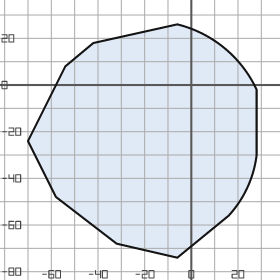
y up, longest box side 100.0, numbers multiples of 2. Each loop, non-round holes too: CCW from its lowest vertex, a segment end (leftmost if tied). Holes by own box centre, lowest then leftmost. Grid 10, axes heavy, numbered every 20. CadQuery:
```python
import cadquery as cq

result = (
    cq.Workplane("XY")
    .moveTo(-6.0, -74.0)
    .lineTo(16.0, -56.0)
    .threePointArc((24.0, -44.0), (28.0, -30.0))
    .lineTo(28.0, -2.0)
    .threePointArc((14.0, 16.0), (-6.0, 26.0))
    .lineTo(-42.0, 18.0)
    .lineTo(-54.0, 8.0)
    .lineTo(-70.0, -24.0)
    .lineTo(-58.0, -48.0)
    .lineTo(-32.0, -68.0)
    .close()
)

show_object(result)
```